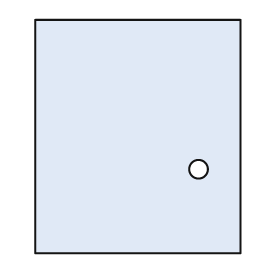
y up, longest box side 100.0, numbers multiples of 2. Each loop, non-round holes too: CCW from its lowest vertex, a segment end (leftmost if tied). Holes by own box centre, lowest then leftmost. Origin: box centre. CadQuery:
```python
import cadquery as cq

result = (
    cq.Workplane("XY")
    .moveTo(-44.0, -50.0)
    .lineTo(44.0, -50.0)
    .lineTo(44.0, 50.0)
    .lineTo(-44.0, 50.0)
    .close()
    .moveTo(26.0, -14.0)
    .circle(4.0)
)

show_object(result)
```